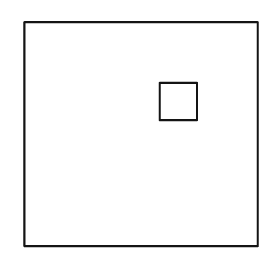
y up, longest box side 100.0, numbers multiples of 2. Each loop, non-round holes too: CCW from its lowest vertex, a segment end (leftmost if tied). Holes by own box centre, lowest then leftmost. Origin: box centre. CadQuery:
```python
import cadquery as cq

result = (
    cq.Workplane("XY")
    .moveTo(-50.0, -48.0)
    .lineTo(50.0, -48.0)
    .lineTo(50.0, 48.0)
    .lineTo(-50.0, 48.0)
    .close()
    .moveTo(8.0, 6.0)
    .lineTo(24.0, 6.0)
    .lineTo(24.0, 22.0)
    .lineTo(8.0, 22.0)
    .close()
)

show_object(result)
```